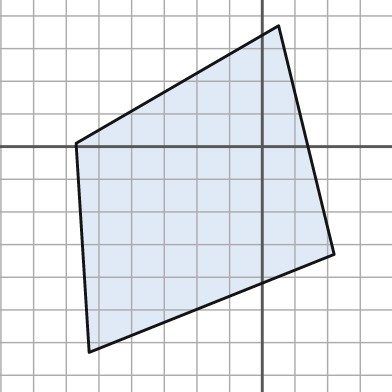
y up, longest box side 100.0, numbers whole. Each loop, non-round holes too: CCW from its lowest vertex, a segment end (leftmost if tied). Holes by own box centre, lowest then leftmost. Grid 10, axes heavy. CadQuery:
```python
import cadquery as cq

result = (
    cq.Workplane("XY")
    .moveTo(-53.0, -63.0)
    .lineTo(22.0, -33.0)
    .lineTo(5.0, 37.0)
    .lineTo(-57.0, 1.0)
    .close()
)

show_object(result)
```